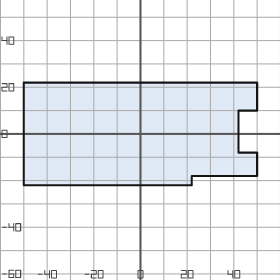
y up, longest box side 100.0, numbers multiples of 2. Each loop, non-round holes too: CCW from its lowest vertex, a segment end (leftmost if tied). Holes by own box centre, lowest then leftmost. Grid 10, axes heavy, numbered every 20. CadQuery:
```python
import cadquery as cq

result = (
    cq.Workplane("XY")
    .moveTo(-50.0, -22.0)
    .lineTo(22.0, -22.0)
    .lineTo(22.0, -18.0)
    .lineTo(50.0, -18.0)
    .lineTo(50.0, -8.0)
    .lineTo(42.0, -8.0)
    .lineTo(42.0, 10.0)
    .lineTo(50.0, 10.0)
    .lineTo(50.0, 22.0)
    .lineTo(-50.0, 22.0)
    .close()
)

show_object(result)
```